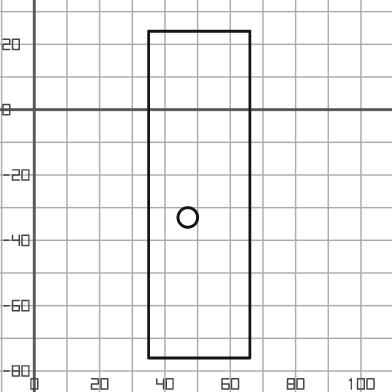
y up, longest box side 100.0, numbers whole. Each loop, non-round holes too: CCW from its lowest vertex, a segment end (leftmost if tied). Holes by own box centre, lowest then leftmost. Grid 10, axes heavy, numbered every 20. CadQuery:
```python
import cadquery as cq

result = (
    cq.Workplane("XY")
    .moveTo(35.0, -76.0)
    .lineTo(66.0, -76.0)
    .lineTo(66.0, 24.0)
    .lineTo(35.0, 24.0)
    .close()
    .moveTo(47.0, -33.0)
    .circle(3.0)
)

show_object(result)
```